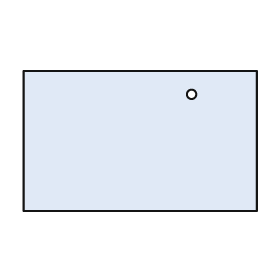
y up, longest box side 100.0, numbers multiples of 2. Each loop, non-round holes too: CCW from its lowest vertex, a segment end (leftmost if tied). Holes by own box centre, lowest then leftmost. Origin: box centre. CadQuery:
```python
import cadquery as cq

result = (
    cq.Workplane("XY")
    .moveTo(-50.0, -30.0)
    .lineTo(50.0, -30.0)
    .lineTo(50.0, 30.0)
    .lineTo(-50.0, 30.0)
    .close()
    .moveTo(22.0, 20.0)
    .circle(2.0)
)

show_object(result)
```